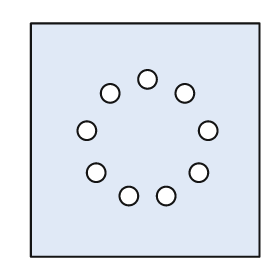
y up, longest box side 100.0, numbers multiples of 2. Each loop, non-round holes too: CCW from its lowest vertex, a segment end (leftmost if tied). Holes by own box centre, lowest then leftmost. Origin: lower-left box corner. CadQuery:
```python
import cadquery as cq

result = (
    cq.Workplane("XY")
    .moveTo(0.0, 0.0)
    .lineTo(98.0, 0.0)
    .lineTo(98.0, 100.0)
    .lineTo(0.0, 100.0)
    .close()
    .moveTo(42.0, 26.0)
    .circle(4.0)
    .moveTo(58.0, 26.0)
    .circle(4.0)
    .moveTo(28.0, 36.0)
    .circle(4.0)
    .moveTo(72.0, 36.0)
    .circle(4.0)
    .moveTo(24.0, 54.0)
    .circle(4.0)
    .moveTo(76.0, 54.0)
    .circle(4.0)
    .moveTo(34.0, 70.0)
    .circle(4.0)
    .moveTo(66.0, 70.0)
    .circle(4.0)
    .moveTo(50.0, 76.0)
    .circle(4.0)
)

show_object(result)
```